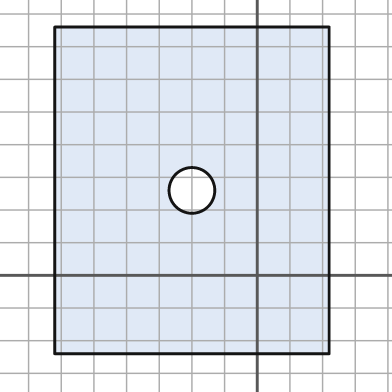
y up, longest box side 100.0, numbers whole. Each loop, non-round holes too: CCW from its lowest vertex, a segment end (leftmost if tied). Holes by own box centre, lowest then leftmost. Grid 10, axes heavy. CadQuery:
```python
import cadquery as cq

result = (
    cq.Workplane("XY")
    .moveTo(-62.0, -24.0)
    .lineTo(22.0, -24.0)
    .lineTo(22.0, 76.0)
    .lineTo(-62.0, 76.0)
    .close()
    .moveTo(-20.0, 26.0)
    .circle(7.0)
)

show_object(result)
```